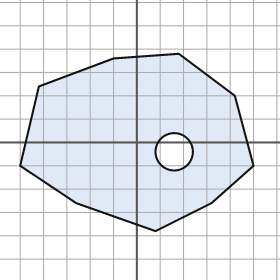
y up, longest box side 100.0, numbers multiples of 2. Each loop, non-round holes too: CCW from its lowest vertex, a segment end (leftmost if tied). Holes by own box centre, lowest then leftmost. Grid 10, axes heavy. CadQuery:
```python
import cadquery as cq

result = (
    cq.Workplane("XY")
    .moveTo(8.0, -38.0)
    .lineTo(32.0, -26.0)
    .lineTo(50.0, -10.0)
    .lineTo(42.0, 20.0)
    .lineTo(18.0, 38.0)
    .lineTo(-10.0, 36.0)
    .lineTo(-42.0, 24.0)
    .lineTo(-50.0, -10.0)
    .lineTo(-26.0, -26.0)
    .close()
    .moveTo(16.0, -4.0)
    .circle(8.0)
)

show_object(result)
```